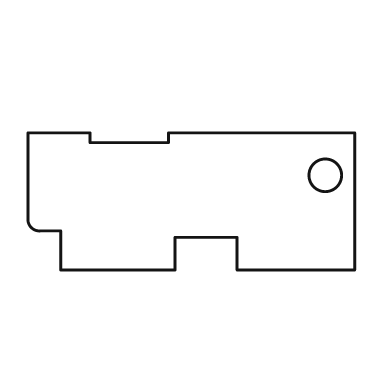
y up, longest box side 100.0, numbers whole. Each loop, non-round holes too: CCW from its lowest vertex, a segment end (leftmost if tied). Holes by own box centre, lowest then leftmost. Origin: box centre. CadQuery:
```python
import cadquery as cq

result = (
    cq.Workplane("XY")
    .moveTo(-40.0, -21.0)
    .lineTo(-5.0, -21.0)
    .lineTo(-5.0, -11.0)
    .lineTo(14.0, -11.0)
    .lineTo(14.0, -21.0)
    .lineTo(50.0, -21.0)
    .lineTo(50.0, 21.0)
    .lineTo(-7.0, 21.0)
    .lineTo(-7.0, 18.0)
    .lineTo(-31.0, 18.0)
    .lineTo(-31.0, 21.0)
    .lineTo(-50.0, 21.0)
    .lineTo(-50.0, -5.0)
    .threePointArc((-49.0, -8.0), (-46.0, -9.0))
    .lineTo(-40.0, -9.0)
    .close()
    .moveTo(41.0, 8.0)
    .circle(5.0)
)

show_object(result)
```